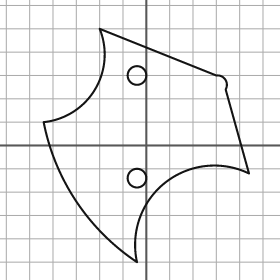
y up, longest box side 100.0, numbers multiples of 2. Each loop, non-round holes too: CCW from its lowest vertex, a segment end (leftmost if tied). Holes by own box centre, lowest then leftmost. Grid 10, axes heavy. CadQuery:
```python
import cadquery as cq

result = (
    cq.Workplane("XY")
    .moveTo(-4.0, -50.0)
    .threePointArc((8.0, -16.0), (44.0, -12.0))
    .lineTo(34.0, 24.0)
    .threePointArc((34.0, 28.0), (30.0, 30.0))
    .lineTo(-20.0, 50.0)
    .threePointArc((-22.0, 24.0), (-44.0, 10.0))
    .threePointArc((-30.0, -24.0), (-4.0, -50.0))
    .close()
    .moveTo(-4.0, -14.0)
    .circle(4.0)
    .moveTo(-4.0, 30.0)
    .circle(4.0)
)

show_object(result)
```